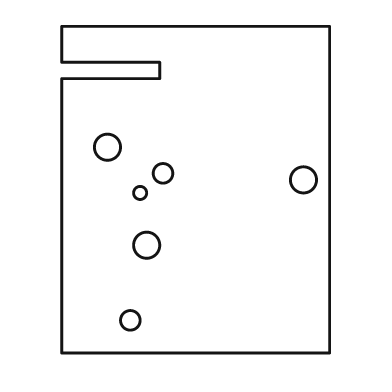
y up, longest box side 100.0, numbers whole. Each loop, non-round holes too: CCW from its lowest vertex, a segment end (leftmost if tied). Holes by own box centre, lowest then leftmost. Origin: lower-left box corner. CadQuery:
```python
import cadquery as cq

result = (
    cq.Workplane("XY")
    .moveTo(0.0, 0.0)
    .lineTo(82.0, 0.0)
    .lineTo(82.0, 100.0)
    .lineTo(0.0, 100.0)
    .lineTo(0.0, 89.0)
    .lineTo(30.0, 89.0)
    .lineTo(30.0, 84.0)
    .lineTo(0.0, 84.0)
    .close()
    .moveTo(21.0, 10.0)
    .circle(3.0)
    .moveTo(26.0, 33.0)
    .circle(4.0)
    .moveTo(24.0, 49.0)
    .circle(2.0)
    .moveTo(74.0, 53.0)
    .circle(4.0)
    .moveTo(31.0, 55.0)
    .circle(3.0)
    .moveTo(14.0, 63.0)
    .circle(4.0)
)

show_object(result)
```